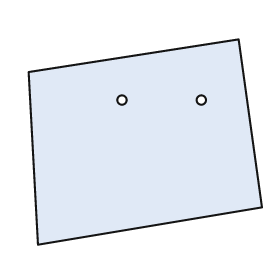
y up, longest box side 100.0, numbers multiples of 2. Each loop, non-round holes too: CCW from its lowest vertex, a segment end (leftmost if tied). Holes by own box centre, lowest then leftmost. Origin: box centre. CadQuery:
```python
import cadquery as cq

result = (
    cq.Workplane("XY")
    .moveTo(-46.0, -44.0)
    .lineTo(50.0, -28.0)
    .lineTo(40.0, 44.0)
    .lineTo(-50.0, 30.0)
    .close()
    .moveTo(-10.0, 18.0)
    .circle(2.0)
    .moveTo(24.0, 18.0)
    .circle(2.0)
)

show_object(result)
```